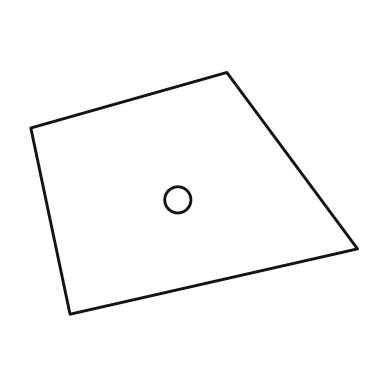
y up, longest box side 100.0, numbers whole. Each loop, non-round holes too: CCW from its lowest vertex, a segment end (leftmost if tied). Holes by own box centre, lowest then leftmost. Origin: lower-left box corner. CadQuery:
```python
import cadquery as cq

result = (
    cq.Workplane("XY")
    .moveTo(12.0, 0.0)
    .lineTo(100.0, 20.0)
    .lineTo(60.0, 74.0)
    .lineTo(0.0, 57.0)
    .close()
    .moveTo(45.0, 35.0)
    .circle(4.0)
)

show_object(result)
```